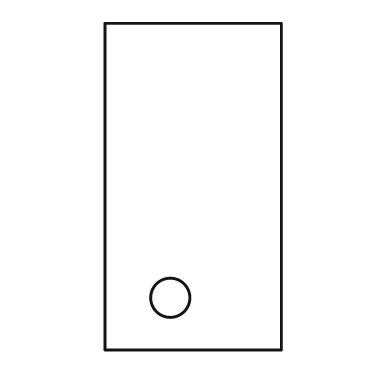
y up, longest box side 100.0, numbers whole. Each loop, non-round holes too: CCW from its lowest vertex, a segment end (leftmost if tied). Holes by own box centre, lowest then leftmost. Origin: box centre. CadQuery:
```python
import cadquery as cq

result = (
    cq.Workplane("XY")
    .moveTo(-27.0, -50.0)
    .lineTo(27.0, -50.0)
    .lineTo(27.0, 50.0)
    .lineTo(-27.0, 50.0)
    .close()
    .moveTo(-7.0, -34.0)
    .circle(6.0)
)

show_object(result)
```